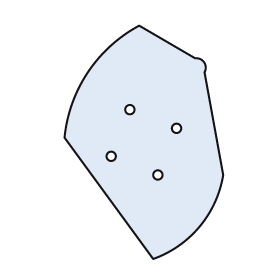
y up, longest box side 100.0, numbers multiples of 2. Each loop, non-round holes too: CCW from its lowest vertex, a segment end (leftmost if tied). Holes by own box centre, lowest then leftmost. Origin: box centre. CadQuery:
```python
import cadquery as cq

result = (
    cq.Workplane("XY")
    .moveTo(4.0, -50.0)
    .threePointArc((24.0, -36.0), (34.0, -14.0))
    .lineTo(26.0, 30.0)
    .threePointArc((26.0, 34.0), (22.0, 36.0))
    .lineTo(-2.0, 50.0)
    .threePointArc((-24.0, 30.0), (-34.0, 2.0))
    .close()
    .moveTo(6.0, -14.0)
    .circle(2.0)
    .moveTo(-14.0, -6.0)
    .circle(2.0)
    .moveTo(14.0, 6.0)
    .circle(2.0)
    .moveTo(-6.0, 14.0)
    .circle(2.0)
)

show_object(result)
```